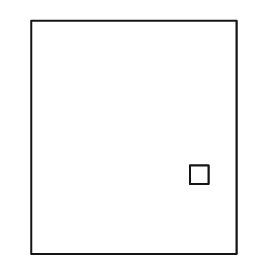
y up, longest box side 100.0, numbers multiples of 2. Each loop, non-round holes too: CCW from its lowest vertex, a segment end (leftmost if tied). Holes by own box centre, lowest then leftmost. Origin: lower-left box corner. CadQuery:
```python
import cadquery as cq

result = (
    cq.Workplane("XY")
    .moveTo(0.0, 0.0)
    .lineTo(88.0, 0.0)
    .lineTo(88.0, 100.0)
    .lineTo(0.0, 100.0)
    .close()
    .moveTo(68.0, 30.0)
    .lineTo(76.0, 30.0)
    .lineTo(76.0, 38.0)
    .lineTo(68.0, 38.0)
    .close()
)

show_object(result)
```